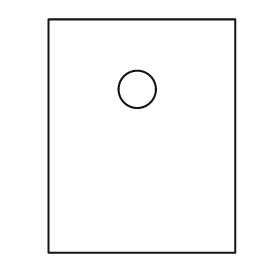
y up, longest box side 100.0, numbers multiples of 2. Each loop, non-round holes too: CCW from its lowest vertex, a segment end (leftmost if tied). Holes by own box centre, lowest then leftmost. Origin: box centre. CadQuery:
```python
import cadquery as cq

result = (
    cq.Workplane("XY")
    .moveTo(-40.0, -50.0)
    .lineTo(40.0, -50.0)
    .lineTo(40.0, 50.0)
    .lineTo(-40.0, 50.0)
    .close()
    .moveTo(-2.0, 20.0)
    .circle(8.0)
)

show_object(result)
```